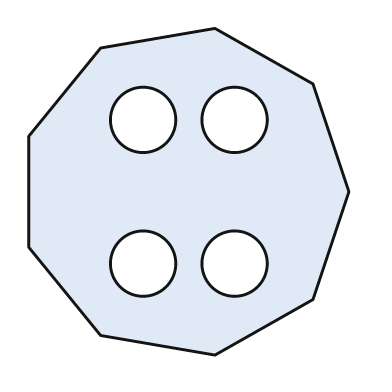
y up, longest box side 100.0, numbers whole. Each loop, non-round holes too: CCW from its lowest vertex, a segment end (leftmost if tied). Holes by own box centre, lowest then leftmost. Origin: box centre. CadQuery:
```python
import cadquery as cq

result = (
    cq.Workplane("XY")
    .moveTo(8.0, -50.0)
    .lineTo(38.0, -33.0)
    .lineTo(49.0, 0.0)
    .lineTo(38.0, 33.0)
    .lineTo(8.0, 50.0)
    .lineTo(-27.0, 44.0)
    .lineTo(-49.0, 17.0)
    .lineTo(-49.0, -17.0)
    .lineTo(-27.0, -44.0)
    .close()
    .moveTo(-14.0, -22.0)
    .circle(10.0)
    .moveTo(14.0, -22.0)
    .circle(10.0)
    .moveTo(-14.0, 22.0)
    .circle(10.0)
    .moveTo(14.0, 22.0)
    .circle(10.0)
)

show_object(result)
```